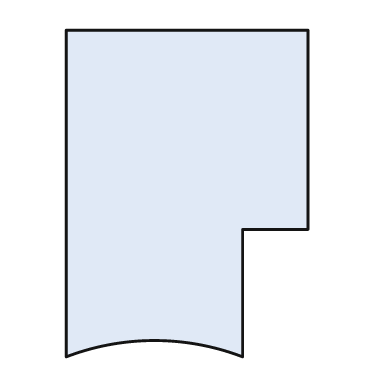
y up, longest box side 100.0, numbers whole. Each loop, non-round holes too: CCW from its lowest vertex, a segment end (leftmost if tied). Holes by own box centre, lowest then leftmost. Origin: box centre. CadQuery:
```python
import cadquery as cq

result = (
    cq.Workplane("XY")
    .moveTo(-37.0, -50.0)
    .threePointArc((-10.0, -45.0), (17.0, -50.0))
    .lineTo(17.0, -11.0)
    .lineTo(37.0, -11.0)
    .lineTo(37.0, 50.0)
    .lineTo(-37.0, 50.0)
    .close()
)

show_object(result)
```